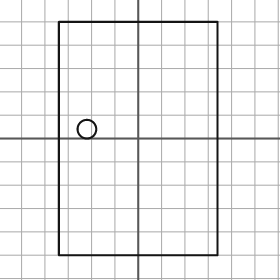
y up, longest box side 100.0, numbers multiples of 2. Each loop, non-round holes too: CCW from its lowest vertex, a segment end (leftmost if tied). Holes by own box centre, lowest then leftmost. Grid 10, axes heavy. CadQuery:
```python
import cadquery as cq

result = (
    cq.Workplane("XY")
    .moveTo(-34.0, -50.0)
    .lineTo(34.0, -50.0)
    .lineTo(34.0, 50.0)
    .lineTo(-34.0, 50.0)
    .close()
    .moveTo(-22.0, 4.0)
    .circle(4.0)
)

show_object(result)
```